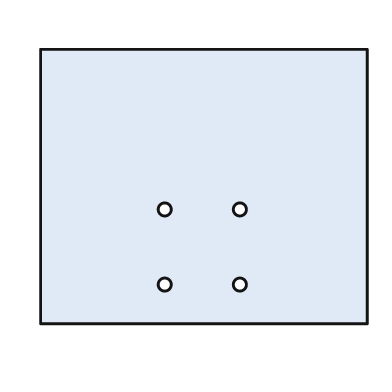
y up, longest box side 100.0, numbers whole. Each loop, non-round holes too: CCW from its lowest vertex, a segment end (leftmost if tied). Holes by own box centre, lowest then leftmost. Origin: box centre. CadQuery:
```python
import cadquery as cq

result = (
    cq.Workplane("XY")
    .moveTo(-50.0, -42.0)
    .lineTo(50.0, -42.0)
    .lineTo(50.0, 42.0)
    .lineTo(-50.0, 42.0)
    .close()
    .moveTo(-12.0, -30.0)
    .circle(2.0)
    .moveTo(11.0, -30.0)
    .circle(2.0)
    .moveTo(-12.0, -7.0)
    .circle(2.0)
    .moveTo(11.0, -7.0)
    .circle(2.0)
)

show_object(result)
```